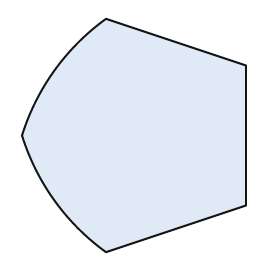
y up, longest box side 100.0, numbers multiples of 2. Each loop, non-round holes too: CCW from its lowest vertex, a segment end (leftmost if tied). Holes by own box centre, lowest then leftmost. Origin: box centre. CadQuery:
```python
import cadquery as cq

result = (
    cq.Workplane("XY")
    .moveTo(-12.0, -50.0)
    .lineTo(48.0, -30.0)
    .lineTo(48.0, 30.0)
    .lineTo(-12.0, 50.0)
    .threePointArc((-34.0, 28.0), (-48.0, 0.0))
    .threePointArc((-34.0, -28.0), (-12.0, -50.0))
    .close()
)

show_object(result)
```